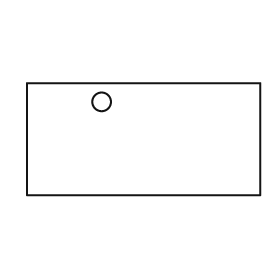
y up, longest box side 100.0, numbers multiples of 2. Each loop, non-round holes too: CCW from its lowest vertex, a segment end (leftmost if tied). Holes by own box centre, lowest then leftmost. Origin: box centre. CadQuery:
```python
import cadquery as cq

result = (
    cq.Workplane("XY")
    .moveTo(-50.0, -24.0)
    .lineTo(50.0, -24.0)
    .lineTo(50.0, 24.0)
    .lineTo(-50.0, 24.0)
    .close()
    .moveTo(-18.0, 16.0)
    .circle(4.0)
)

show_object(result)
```